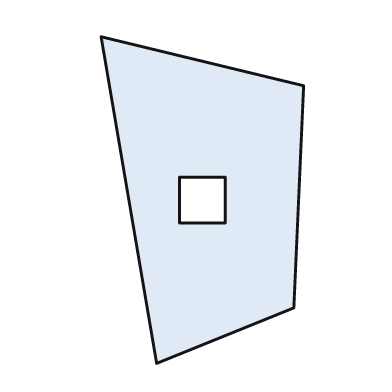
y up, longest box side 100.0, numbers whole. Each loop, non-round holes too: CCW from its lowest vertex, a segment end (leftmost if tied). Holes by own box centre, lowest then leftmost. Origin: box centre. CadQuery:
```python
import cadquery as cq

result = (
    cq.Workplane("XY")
    .moveTo(-14.0, -50.0)
    .lineTo(28.0, -33.0)
    .lineTo(31.0, 35.0)
    .lineTo(-31.0, 50.0)
    .close()
    .moveTo(-7.0, -7.0)
    .lineTo(7.0, -7.0)
    .lineTo(7.0, 7.0)
    .lineTo(-7.0, 7.0)
    .close()
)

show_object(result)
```